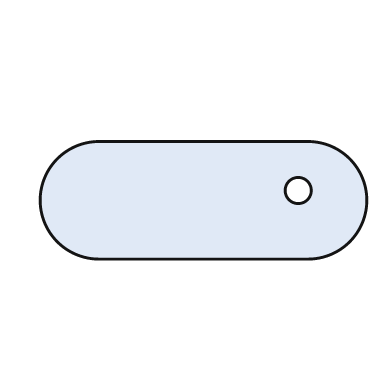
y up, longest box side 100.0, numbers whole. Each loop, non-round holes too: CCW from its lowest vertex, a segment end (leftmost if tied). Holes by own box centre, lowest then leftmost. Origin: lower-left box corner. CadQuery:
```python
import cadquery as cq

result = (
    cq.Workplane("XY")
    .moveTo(18.0, 0.0)
    .lineTo(82.0, 0.0)
    .threePointArc((100.0, 18.0), (82.0, 36.0))
    .lineTo(18.0, 36.0)
    .threePointArc((0.0, 18.0), (18.0, 0.0))
    .close()
    .moveTo(79.0, 21.0)
    .circle(4.0)
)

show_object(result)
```